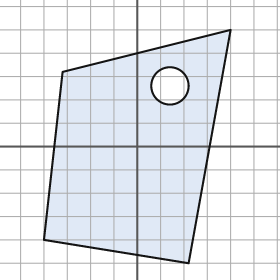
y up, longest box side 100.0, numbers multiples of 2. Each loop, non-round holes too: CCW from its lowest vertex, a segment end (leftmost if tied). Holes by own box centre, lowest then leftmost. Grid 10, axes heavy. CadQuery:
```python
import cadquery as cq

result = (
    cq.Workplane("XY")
    .moveTo(22.0, -50.0)
    .lineTo(40.0, 50.0)
    .lineTo(-32.0, 32.0)
    .lineTo(-40.0, -40.0)
    .close()
    .moveTo(14.0, 26.0)
    .circle(8.0)
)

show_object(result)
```